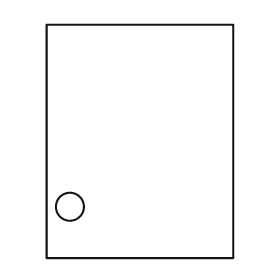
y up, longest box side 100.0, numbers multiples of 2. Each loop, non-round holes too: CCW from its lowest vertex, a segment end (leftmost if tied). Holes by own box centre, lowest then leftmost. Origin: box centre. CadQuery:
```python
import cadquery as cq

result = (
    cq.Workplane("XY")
    .moveTo(-40.0, -50.0)
    .lineTo(40.0, -50.0)
    .lineTo(40.0, 50.0)
    .lineTo(-40.0, 50.0)
    .close()
    .moveTo(-30.0, -28.0)
    .circle(6.0)
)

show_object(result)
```